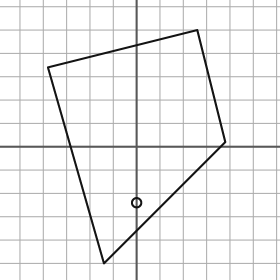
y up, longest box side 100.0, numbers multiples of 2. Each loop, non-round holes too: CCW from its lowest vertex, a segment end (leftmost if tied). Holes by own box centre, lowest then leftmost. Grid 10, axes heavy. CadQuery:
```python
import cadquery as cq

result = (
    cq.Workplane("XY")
    .moveTo(-14.0, -50.0)
    .lineTo(38.0, 2.0)
    .lineTo(26.0, 50.0)
    .lineTo(-38.0, 34.0)
    .close()
    .moveTo(0.0, -24.0)
    .circle(2.0)
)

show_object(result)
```